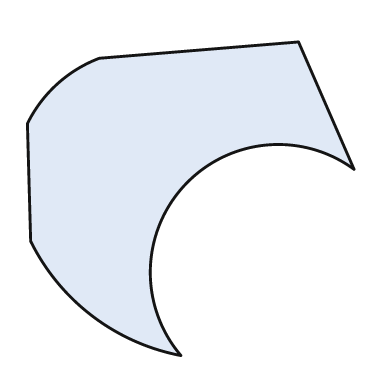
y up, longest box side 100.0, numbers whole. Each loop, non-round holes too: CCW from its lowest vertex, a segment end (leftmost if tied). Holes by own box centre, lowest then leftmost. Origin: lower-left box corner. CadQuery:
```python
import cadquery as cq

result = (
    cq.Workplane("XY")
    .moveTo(47.0, 0.0)
    .threePointArc((48.0, 52.0), (100.0, 57.0))
    .lineTo(83.0, 96.0)
    .lineTo(22.0, 91.0)
    .threePointArc((9.0, 83.0), (0.0, 71.0))
    .lineTo(1.0, 35.0)
    .threePointArc((20.0, 12.0), (47.0, 0.0))
    .close()
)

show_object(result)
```